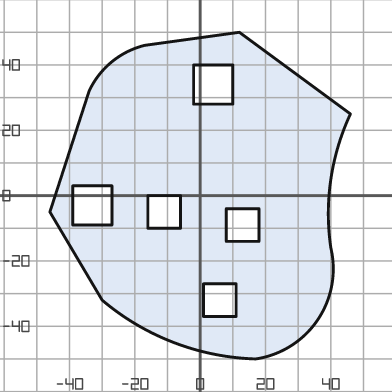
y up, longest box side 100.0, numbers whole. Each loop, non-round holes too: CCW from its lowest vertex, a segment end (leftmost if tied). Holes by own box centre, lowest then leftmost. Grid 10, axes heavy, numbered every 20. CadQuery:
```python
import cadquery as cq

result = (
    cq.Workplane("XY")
    .moveTo(17.0, -50.0)
    .threePointArc((36.0, -38.0), (40.0, -16.0))
    .threePointArc((40.0, 5.0), (46.0, 25.0))
    .lineTo(12.0, 50.0)
    .lineTo(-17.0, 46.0)
    .threePointArc((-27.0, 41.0), (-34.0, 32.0))
    .lineTo(-46.0, -5.0)
    .lineTo(-30.0, -32.0)
    .threePointArc((-8.0, -45.0), (17.0, -50.0))
    .close()
    .moveTo(1.0, -37.0)
    .lineTo(11.0, -37.0)
    .lineTo(11.0, -27.0)
    .lineTo(1.0, -27.0)
    .close()
    .moveTo(8.0, -14.0)
    .lineTo(18.0, -14.0)
    .lineTo(18.0, -4.0)
    .lineTo(8.0, -4.0)
    .close()
    .moveTo(-16.0, -10.0)
    .lineTo(-6.0, -10.0)
    .lineTo(-6.0, 0.0)
    .lineTo(-16.0, 0.0)
    .close()
    .moveTo(-39.0, -9.0)
    .lineTo(-27.0, -9.0)
    .lineTo(-27.0, 3.0)
    .lineTo(-39.0, 3.0)
    .close()
    .moveTo(-2.0, 28.0)
    .lineTo(10.0, 28.0)
    .lineTo(10.0, 40.0)
    .lineTo(-2.0, 40.0)
    .close()
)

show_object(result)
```